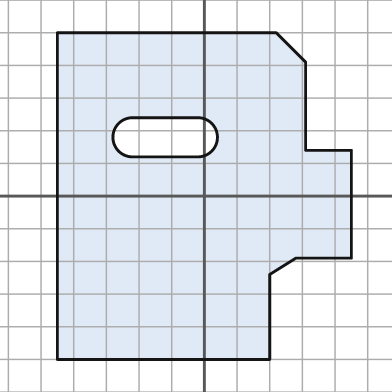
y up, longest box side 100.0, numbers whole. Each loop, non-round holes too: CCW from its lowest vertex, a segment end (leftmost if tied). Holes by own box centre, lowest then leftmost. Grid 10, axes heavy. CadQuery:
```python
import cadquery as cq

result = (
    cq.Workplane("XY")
    .moveTo(-45.0, -50.0)
    .lineTo(20.0, -50.0)
    .lineTo(20.0, -24.0)
    .lineTo(28.0, -19.0)
    .lineTo(45.0, -19.0)
    .lineTo(45.0, 14.0)
    .lineTo(31.0, 14.0)
    .lineTo(31.0, 41.0)
    .lineTo(22.0, 50.0)
    .lineTo(-45.0, 50.0)
    .close()
    .moveTo(-22.0, 12.0)
    .lineTo(-2.0, 12.0)
    .threePointArc((4.0, 18.0), (-2.0, 24.0))
    .lineTo(-22.0, 24.0)
    .threePointArc((-28.0, 18.0), (-22.0, 12.0))
    .close()
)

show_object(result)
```